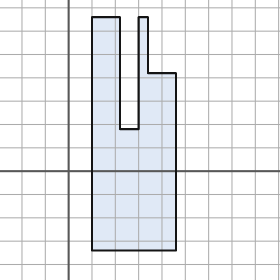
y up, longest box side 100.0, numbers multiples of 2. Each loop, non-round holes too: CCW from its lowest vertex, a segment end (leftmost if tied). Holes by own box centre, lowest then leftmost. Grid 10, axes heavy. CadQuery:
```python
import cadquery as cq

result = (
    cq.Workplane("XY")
    .moveTo(10.0, -34.0)
    .lineTo(46.0, -34.0)
    .lineTo(46.0, 42.0)
    .lineTo(34.0, 42.0)
    .lineTo(34.0, 66.0)
    .lineTo(30.0, 66.0)
    .lineTo(30.0, 18.0)
    .lineTo(22.0, 18.0)
    .lineTo(22.0, 66.0)
    .lineTo(10.0, 66.0)
    .close()
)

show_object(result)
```